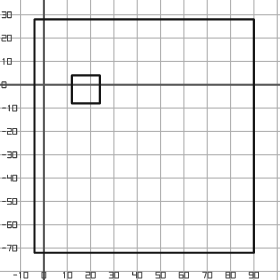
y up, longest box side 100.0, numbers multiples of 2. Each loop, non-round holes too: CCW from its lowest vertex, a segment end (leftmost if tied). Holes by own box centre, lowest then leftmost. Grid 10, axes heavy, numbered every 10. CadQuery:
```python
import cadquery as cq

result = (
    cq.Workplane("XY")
    .moveTo(-4.0, -72.0)
    .lineTo(90.0, -72.0)
    .lineTo(90.0, 28.0)
    .lineTo(-4.0, 28.0)
    .close()
    .moveTo(12.0, -8.0)
    .lineTo(24.0, -8.0)
    .lineTo(24.0, 4.0)
    .lineTo(12.0, 4.0)
    .close()
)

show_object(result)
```